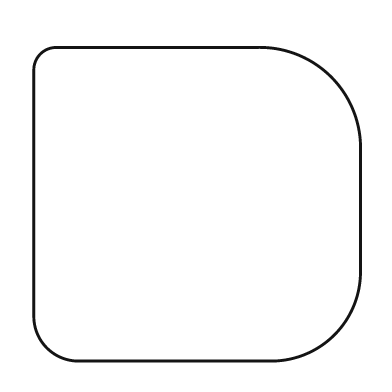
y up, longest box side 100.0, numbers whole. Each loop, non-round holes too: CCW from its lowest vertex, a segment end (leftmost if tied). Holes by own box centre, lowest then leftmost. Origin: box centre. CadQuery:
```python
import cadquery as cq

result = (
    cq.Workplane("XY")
    .moveTo(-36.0, -48.0)
    .lineTo(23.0, -48.0)
    .threePointArc((42.0, -40.0), (50.0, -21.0))
    .lineTo(50.0, 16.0)
    .threePointArc((41.0, 39.0), (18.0, 48.0))
    .lineTo(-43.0, 48.0)
    .threePointArc((-48.0, 46.0), (-50.0, 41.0))
    .lineTo(-50.0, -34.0)
    .threePointArc((-46.0, -44.0), (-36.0, -48.0))
    .close()
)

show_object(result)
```